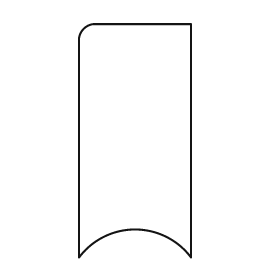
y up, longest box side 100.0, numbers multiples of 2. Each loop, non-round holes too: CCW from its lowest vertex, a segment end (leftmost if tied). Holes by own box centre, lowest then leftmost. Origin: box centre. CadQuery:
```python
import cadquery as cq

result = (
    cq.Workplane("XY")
    .moveTo(-24.0, -50.0)
    .threePointArc((0.0, -38.0), (24.0, -50.0))
    .lineTo(24.0, 50.0)
    .lineTo(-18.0, 50.0)
    .threePointArc((-22.0, 48.0), (-24.0, 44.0))
    .close()
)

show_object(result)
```